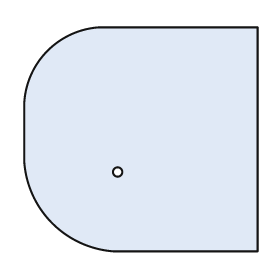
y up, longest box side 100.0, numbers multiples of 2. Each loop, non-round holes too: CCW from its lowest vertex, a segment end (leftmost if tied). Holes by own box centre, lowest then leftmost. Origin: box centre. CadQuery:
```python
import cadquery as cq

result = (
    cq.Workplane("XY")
    .moveTo(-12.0, -48.0)
    .lineTo(50.0, -48.0)
    .lineTo(50.0, 48.0)
    .lineTo(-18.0, 48.0)
    .threePointArc((-40.0, 38.0), (-50.0, 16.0))
    .lineTo(-50.0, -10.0)
    .threePointArc((-38.0, -36.0), (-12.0, -48.0))
    .close()
    .moveTo(-10.0, -14.0)
    .circle(2.0)
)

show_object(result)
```